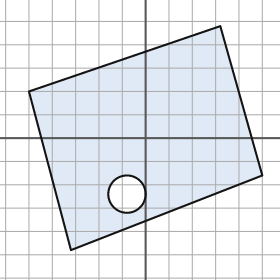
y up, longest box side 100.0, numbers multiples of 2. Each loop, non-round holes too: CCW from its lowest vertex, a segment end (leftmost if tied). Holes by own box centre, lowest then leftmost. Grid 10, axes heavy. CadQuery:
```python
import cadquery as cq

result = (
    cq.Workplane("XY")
    .moveTo(-32.0, -48.0)
    .lineTo(50.0, -16.0)
    .lineTo(32.0, 48.0)
    .lineTo(-50.0, 20.0)
    .close()
    .moveTo(-8.0, -24.0)
    .circle(8.0)
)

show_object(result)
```